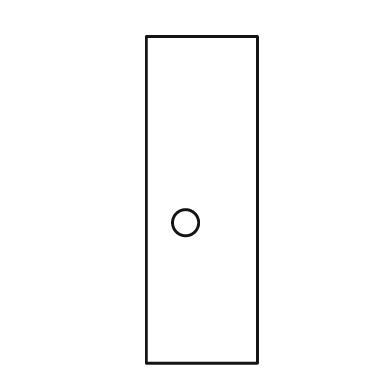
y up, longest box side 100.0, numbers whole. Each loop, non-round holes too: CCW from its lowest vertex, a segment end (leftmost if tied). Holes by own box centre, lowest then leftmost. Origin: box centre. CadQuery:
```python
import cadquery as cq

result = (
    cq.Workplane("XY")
    .moveTo(-17.0, -50.0)
    .lineTo(17.0, -50.0)
    .lineTo(17.0, 50.0)
    .lineTo(-17.0, 50.0)
    .close()
    .moveTo(-5.0, -7.0)
    .circle(4.0)
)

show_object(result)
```